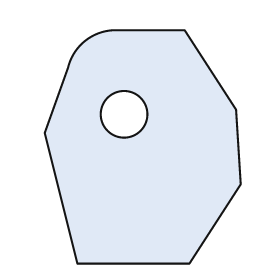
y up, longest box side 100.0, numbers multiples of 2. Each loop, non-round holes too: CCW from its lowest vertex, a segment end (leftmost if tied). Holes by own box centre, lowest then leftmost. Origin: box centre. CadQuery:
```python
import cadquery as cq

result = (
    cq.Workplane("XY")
    .moveTo(-28.0, -50.0)
    .lineTo(20.0, -50.0)
    .lineTo(42.0, -16.0)
    .lineTo(40.0, 16.0)
    .lineTo(18.0, 50.0)
    .lineTo(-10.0, 50.0)
    .threePointArc((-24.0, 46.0), (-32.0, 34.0))
    .lineTo(-42.0, 6.0)
    .close()
    .moveTo(-8.0, 14.0)
    .circle(10.0)
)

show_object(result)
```